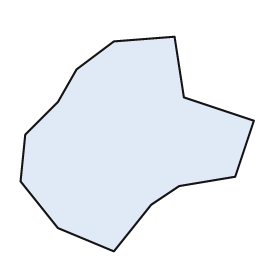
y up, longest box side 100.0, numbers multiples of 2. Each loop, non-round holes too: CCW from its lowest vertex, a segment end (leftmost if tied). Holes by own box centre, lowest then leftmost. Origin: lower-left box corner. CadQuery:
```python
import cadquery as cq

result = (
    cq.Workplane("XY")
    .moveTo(40.0, 0.0)
    .lineTo(56.0, 20.0)
    .lineTo(68.0, 28.0)
    .lineTo(92.0, 32.0)
    .lineTo(100.0, 56.0)
    .lineTo(70.0, 66.0)
    .lineTo(66.0, 92.0)
    .lineTo(40.0, 90.0)
    .lineTo(24.0, 78.0)
    .lineTo(16.0, 64.0)
    .lineTo(2.0, 50.0)
    .lineTo(0.0, 30.0)
    .lineTo(16.0, 10.0)
    .close()
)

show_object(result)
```